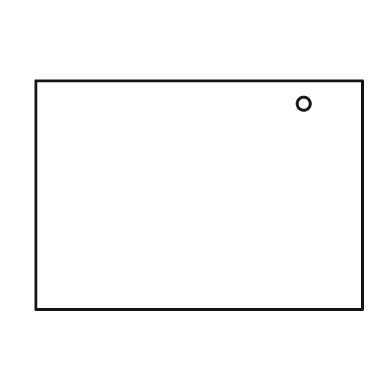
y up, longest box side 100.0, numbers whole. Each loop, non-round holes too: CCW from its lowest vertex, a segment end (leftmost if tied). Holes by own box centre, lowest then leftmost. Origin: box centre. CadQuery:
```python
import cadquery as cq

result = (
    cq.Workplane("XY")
    .moveTo(-50.0, -35.0)
    .lineTo(50.0, -35.0)
    .lineTo(50.0, 35.0)
    .lineTo(-50.0, 35.0)
    .close()
    .moveTo(32.0, 28.0)
    .circle(2.0)
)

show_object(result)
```